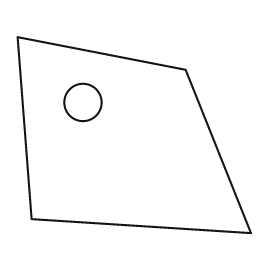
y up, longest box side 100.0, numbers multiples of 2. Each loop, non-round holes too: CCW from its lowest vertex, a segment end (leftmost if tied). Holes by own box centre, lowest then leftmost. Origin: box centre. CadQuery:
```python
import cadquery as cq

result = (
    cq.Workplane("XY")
    .moveTo(50.0, -42.0)
    .lineTo(22.0, 28.0)
    .lineTo(-50.0, 42.0)
    .lineTo(-44.0, -36.0)
    .close()
    .moveTo(-22.0, 14.0)
    .circle(8.0)
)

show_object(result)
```